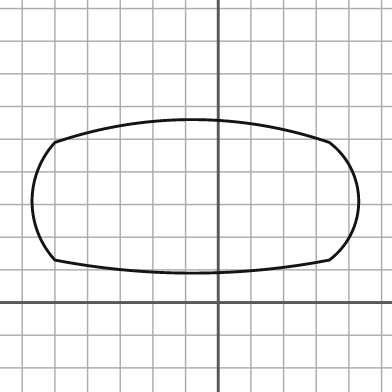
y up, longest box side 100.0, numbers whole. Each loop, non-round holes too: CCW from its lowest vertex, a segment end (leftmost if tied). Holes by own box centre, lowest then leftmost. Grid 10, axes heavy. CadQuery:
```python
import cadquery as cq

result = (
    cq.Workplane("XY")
    .moveTo(-50.0, 13.0)
    .threePointArc((-8.0, 9.0), (34.0, 13.0))
    .threePointArc((43.0, 31.0), (34.0, 49.0))
    .threePointArc((-8.0, 56.0), (-50.0, 49.0))
    .threePointArc((-57.0, 31.0), (-50.0, 13.0))
    .close()
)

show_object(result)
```